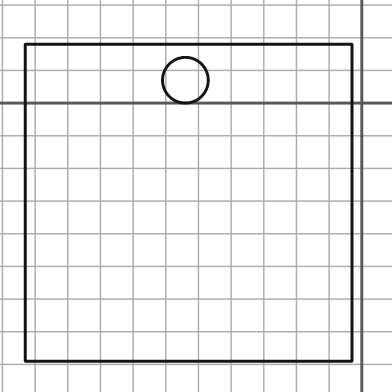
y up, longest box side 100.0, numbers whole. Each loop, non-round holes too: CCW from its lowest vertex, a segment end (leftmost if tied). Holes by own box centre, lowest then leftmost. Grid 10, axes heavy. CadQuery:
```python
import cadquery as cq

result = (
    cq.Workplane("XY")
    .moveTo(-103.0, -79.0)
    .lineTo(-3.0, -79.0)
    .lineTo(-3.0, 18.0)
    .lineTo(-103.0, 18.0)
    .close()
    .moveTo(-54.0, 7.0)
    .circle(7.0)
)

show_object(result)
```